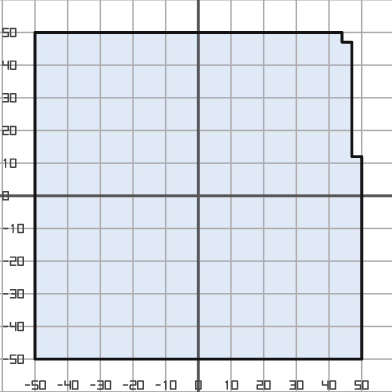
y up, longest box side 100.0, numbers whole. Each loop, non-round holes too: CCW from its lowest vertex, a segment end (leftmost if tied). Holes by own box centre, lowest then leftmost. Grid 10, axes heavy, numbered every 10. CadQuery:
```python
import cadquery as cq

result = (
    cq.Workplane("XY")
    .moveTo(-50.0, -50.0)
    .lineTo(50.0, -50.0)
    .lineTo(50.0, 12.0)
    .lineTo(47.0, 12.0)
    .lineTo(47.0, 47.0)
    .lineTo(44.0, 47.0)
    .lineTo(44.0, 50.0)
    .lineTo(-50.0, 50.0)
    .close()
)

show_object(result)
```